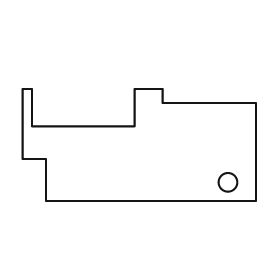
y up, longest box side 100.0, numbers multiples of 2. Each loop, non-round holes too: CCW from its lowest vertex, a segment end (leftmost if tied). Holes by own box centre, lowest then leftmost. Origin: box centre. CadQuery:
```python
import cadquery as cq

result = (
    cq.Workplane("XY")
    .moveTo(-40.0, -24.0)
    .lineTo(50.0, -24.0)
    .lineTo(50.0, 18.0)
    .lineTo(10.0, 18.0)
    .lineTo(10.0, 24.0)
    .lineTo(-2.0, 24.0)
    .lineTo(-2.0, 8.0)
    .lineTo(-46.0, 8.0)
    .lineTo(-46.0, 24.0)
    .lineTo(-50.0, 24.0)
    .lineTo(-50.0, -6.0)
    .lineTo(-40.0, -6.0)
    .close()
    .moveTo(38.0, -16.0)
    .circle(4.0)
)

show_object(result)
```